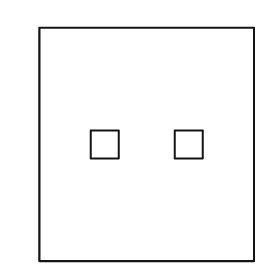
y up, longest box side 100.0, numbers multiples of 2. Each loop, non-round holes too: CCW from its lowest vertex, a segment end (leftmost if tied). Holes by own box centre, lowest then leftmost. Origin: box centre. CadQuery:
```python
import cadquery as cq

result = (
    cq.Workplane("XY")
    .moveTo(-46.0, -50.0)
    .lineTo(46.0, -50.0)
    .lineTo(46.0, 50.0)
    .lineTo(-46.0, 50.0)
    .close()
    .moveTo(-24.0, -6.0)
    .lineTo(-12.0, -6.0)
    .lineTo(-12.0, 6.0)
    .lineTo(-24.0, 6.0)
    .close()
    .moveTo(12.0, -6.0)
    .lineTo(24.0, -6.0)
    .lineTo(24.0, 6.0)
    .lineTo(12.0, 6.0)
    .close()
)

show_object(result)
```